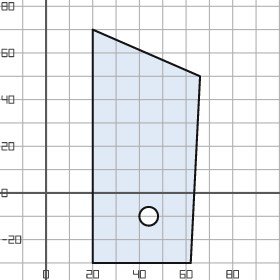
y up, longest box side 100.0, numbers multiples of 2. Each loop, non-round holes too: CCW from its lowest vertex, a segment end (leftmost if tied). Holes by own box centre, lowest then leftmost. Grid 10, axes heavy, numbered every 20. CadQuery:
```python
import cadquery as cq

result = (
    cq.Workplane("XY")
    .moveTo(20.0, -30.0)
    .lineTo(62.0, -30.0)
    .lineTo(66.0, 50.0)
    .lineTo(20.0, 70.0)
    .close()
    .moveTo(44.0, -10.0)
    .circle(4.0)
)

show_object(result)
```